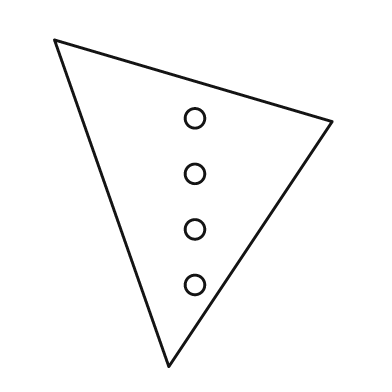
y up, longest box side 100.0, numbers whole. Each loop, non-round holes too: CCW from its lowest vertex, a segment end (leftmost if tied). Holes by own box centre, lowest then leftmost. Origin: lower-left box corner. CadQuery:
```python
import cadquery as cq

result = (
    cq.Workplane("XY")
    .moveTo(35.0, 0.0)
    .lineTo(85.0, 75.0)
    .lineTo(0.0, 100.0)
    .close()
    .moveTo(43.0, 25.0)
    .circle(3.0)
    .moveTo(43.0, 42.0)
    .circle(3.0)
    .moveTo(43.0, 59.0)
    .circle(3.0)
    .moveTo(43.0, 76.0)
    .circle(3.0)
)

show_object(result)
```